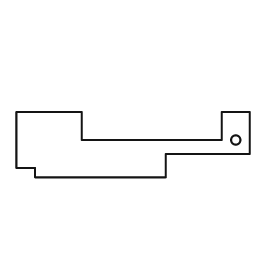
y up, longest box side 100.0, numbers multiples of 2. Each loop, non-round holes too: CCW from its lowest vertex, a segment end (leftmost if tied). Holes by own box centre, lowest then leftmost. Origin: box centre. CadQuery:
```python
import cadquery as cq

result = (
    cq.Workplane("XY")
    .moveTo(-42.0, -14.0)
    .lineTo(14.0, -14.0)
    .lineTo(14.0, -4.0)
    .lineTo(50.0, -4.0)
    .lineTo(50.0, 14.0)
    .lineTo(38.0, 14.0)
    .lineTo(38.0, 2.0)
    .lineTo(-22.0, 2.0)
    .lineTo(-22.0, 14.0)
    .lineTo(-50.0, 14.0)
    .lineTo(-50.0, -10.0)
    .lineTo(-42.0, -10.0)
    .close()
    .moveTo(44.0, 2.0)
    .circle(2.0)
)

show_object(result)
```